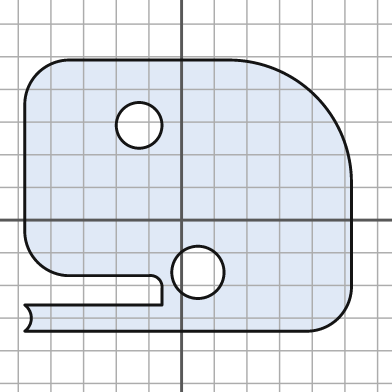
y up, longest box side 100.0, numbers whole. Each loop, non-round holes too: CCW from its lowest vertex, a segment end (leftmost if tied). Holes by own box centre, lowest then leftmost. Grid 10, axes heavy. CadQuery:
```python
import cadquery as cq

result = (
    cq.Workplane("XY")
    .moveTo(-48.0, -34.0)
    .lineTo(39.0, -34.0)
    .threePointArc((48.0, -30.0), (52.0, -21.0))
    .lineTo(52.0, 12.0)
    .threePointArc((41.0, 38.0), (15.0, 49.0))
    .lineTo(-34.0, 49.0)
    .threePointArc((-44.0, 45.0), (-48.0, 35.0))
    .lineTo(-48.0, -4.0)
    .threePointArc((-44.0, -13.0), (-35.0, -17.0))
    .lineTo(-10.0, -17.0)
    .threePointArc((-7.0, -18.0), (-6.0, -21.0))
    .lineTo(-6.0, -26.0)
    .lineTo(-48.0, -26.0)
    .threePointArc((-46.0, -30.0), (-48.0, -34.0))
    .close()
    .moveTo(5.0, -16.0)
    .circle(8.0)
    .moveTo(-13.0, 29.0)
    .circle(7.0)
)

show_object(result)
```